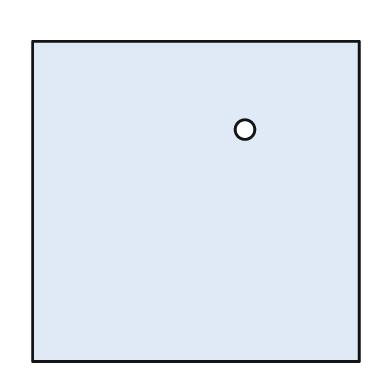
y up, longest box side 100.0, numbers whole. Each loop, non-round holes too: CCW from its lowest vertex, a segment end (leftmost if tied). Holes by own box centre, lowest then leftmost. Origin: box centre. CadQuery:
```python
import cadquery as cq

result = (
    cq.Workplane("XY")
    .moveTo(-50.0, -49.0)
    .lineTo(50.0, -49.0)
    .lineTo(50.0, 49.0)
    .lineTo(-50.0, 49.0)
    .close()
    .moveTo(15.0, 22.0)
    .circle(3.0)
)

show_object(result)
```